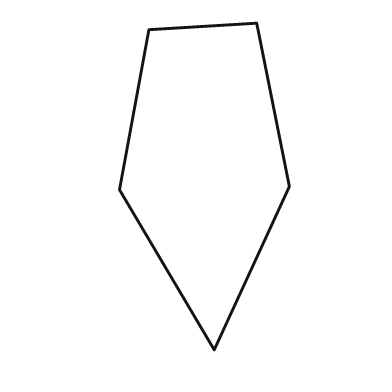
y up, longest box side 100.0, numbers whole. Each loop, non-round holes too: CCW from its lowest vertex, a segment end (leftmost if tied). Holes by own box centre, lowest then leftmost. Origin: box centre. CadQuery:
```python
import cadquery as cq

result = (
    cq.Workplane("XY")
    .moveTo(3.0, -50.0)
    .lineTo(26.0, 0.0)
    .lineTo(16.0, 50.0)
    .lineTo(-17.0, 48.0)
    .lineTo(-26.0, -1.0)
    .close()
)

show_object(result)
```